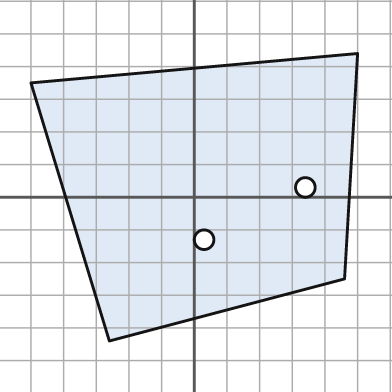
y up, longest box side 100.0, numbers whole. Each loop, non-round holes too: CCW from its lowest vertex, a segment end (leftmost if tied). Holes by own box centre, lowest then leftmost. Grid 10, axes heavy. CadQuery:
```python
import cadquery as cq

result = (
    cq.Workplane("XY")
    .moveTo(-26.0, -44.0)
    .lineTo(46.0, -25.0)
    .lineTo(50.0, 44.0)
    .lineTo(-50.0, 35.0)
    .close()
    .moveTo(3.0, -13.0)
    .circle(3.0)
    .moveTo(34.0, 3.0)
    .circle(3.0)
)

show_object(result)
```